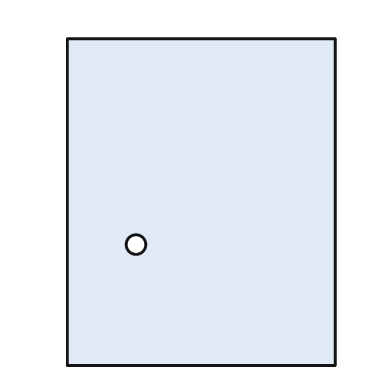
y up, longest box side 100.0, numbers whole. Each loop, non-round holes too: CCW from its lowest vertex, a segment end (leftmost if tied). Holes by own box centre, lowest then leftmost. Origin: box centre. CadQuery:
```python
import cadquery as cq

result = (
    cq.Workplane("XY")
    .moveTo(-41.0, -50.0)
    .lineTo(41.0, -50.0)
    .lineTo(41.0, 50.0)
    .lineTo(-41.0, 50.0)
    .close()
    .moveTo(-20.0, -13.0)
    .circle(3.0)
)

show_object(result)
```